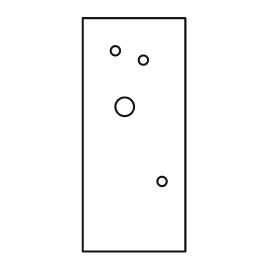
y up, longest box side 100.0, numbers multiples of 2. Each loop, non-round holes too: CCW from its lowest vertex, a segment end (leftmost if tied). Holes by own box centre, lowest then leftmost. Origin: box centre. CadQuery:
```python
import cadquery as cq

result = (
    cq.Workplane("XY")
    .moveTo(-22.0, -50.0)
    .lineTo(22.0, -50.0)
    .lineTo(22.0, 50.0)
    .lineTo(-22.0, 50.0)
    .close()
    .moveTo(12.0, -20.0)
    .circle(2.0)
    .moveTo(-4.0, 12.0)
    .circle(4.0)
    .moveTo(4.0, 32.0)
    .circle(2.0)
    .moveTo(-8.0, 36.0)
    .circle(2.0)
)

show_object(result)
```